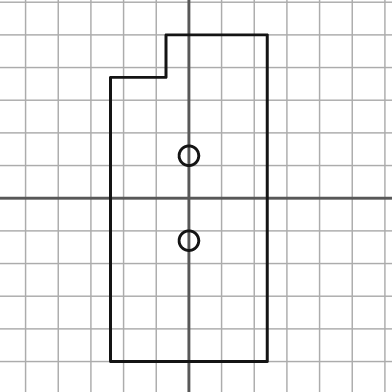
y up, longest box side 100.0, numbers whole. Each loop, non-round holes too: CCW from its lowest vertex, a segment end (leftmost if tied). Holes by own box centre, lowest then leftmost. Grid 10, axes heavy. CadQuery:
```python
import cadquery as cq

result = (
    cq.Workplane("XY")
    .moveTo(-24.0, -50.0)
    .lineTo(24.0, -50.0)
    .lineTo(24.0, 50.0)
    .lineTo(-7.0, 50.0)
    .lineTo(-7.0, 37.0)
    .lineTo(-24.0, 37.0)
    .close()
    .moveTo(0.0, -13.0)
    .circle(3.0)
    .moveTo(0.0, 13.0)
    .circle(3.0)
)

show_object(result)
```